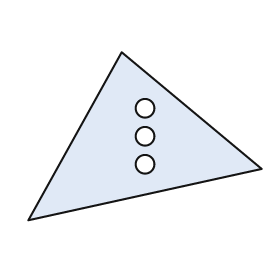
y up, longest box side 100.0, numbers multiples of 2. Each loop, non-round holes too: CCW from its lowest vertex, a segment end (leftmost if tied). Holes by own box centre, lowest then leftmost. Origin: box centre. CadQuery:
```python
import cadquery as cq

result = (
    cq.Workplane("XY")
    .moveTo(-50.0, -36.0)
    .lineTo(50.0, -14.0)
    .lineTo(-10.0, 36.0)
    .close()
    .moveTo(0.0, -12.0)
    .circle(4.0)
    .moveTo(0.0, 0.0)
    .circle(4.0)
    .moveTo(0.0, 12.0)
    .circle(4.0)
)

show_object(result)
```